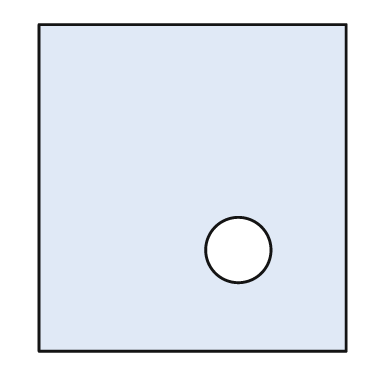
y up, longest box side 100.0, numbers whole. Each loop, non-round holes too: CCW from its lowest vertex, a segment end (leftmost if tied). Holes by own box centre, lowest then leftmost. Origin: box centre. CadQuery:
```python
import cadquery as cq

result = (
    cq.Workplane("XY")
    .moveTo(-47.0, -50.0)
    .lineTo(47.0, -50.0)
    .lineTo(47.0, 50.0)
    .lineTo(-47.0, 50.0)
    .close()
    .moveTo(14.0, -19.0)
    .circle(10.0)
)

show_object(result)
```